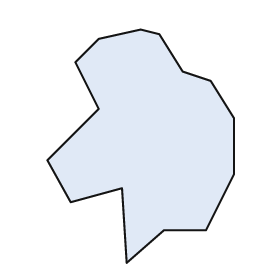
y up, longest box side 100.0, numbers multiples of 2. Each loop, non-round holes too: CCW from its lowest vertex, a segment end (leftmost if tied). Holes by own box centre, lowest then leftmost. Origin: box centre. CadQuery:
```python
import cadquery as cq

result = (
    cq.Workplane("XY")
    .moveTo(-6.0, -50.0)
    .lineTo(10.0, -36.0)
    .lineTo(28.0, -36.0)
    .lineTo(40.0, -12.0)
    .lineTo(40.0, 12.0)
    .lineTo(30.0, 28.0)
    .lineTo(18.0, 32.0)
    .lineTo(8.0, 48.0)
    .lineTo(0.0, 50.0)
    .lineTo(-18.0, 46.0)
    .lineTo(-28.0, 36.0)
    .lineTo(-18.0, 16.0)
    .lineTo(-40.0, -6.0)
    .lineTo(-30.0, -24.0)
    .lineTo(-8.0, -18.0)
    .close()
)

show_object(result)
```